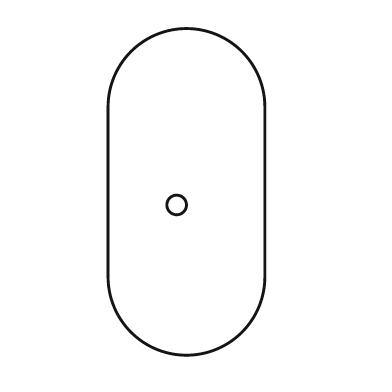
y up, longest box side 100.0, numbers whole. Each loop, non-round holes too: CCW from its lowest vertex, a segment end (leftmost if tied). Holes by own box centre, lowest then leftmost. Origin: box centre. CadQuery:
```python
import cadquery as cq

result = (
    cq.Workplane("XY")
    .moveTo(-24.0, -26.0)
    .threePointArc((0.0, -50.0), (24.0, -26.0))
    .lineTo(24.0, 26.0)
    .threePointArc((0.0, 50.0), (-24.0, 26.0))
    .close()
    .moveTo(-3.0, -4.0)
    .circle(3.0)
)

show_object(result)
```